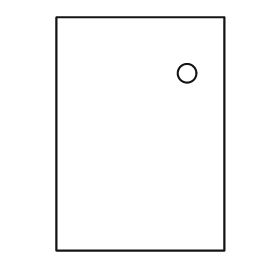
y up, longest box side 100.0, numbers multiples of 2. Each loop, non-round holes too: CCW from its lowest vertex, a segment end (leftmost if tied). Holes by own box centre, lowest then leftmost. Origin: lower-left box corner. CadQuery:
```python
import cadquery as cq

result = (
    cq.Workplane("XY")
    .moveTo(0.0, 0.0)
    .lineTo(72.0, 0.0)
    .lineTo(72.0, 100.0)
    .lineTo(0.0, 100.0)
    .close()
    .moveTo(56.0, 76.0)
    .circle(4.0)
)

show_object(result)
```